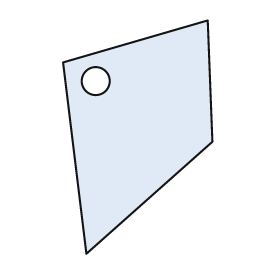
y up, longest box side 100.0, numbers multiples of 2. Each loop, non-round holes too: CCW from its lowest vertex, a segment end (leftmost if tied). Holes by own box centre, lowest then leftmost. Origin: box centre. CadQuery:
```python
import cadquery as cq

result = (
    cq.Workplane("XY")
    .moveTo(-22.0, -50.0)
    .lineTo(32.0, -2.0)
    .lineTo(30.0, 50.0)
    .lineTo(-32.0, 32.0)
    .close()
    .moveTo(-18.0, 24.0)
    .circle(6.0)
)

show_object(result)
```